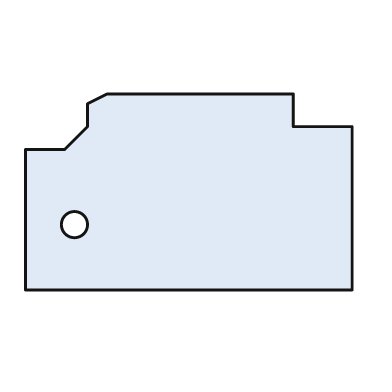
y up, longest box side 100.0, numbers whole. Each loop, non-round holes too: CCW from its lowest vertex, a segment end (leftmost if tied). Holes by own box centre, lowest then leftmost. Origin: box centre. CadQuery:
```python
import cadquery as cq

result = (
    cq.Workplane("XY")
    .moveTo(-50.0, -30.0)
    .lineTo(50.0, -30.0)
    .lineTo(50.0, 20.0)
    .lineTo(32.0, 20.0)
    .lineTo(32.0, 30.0)
    .lineTo(-25.0, 30.0)
    .lineTo(-31.0, 27.0)
    .lineTo(-31.0, 20.0)
    .lineTo(-38.0, 13.0)
    .lineTo(-50.0, 13.0)
    .close()
    .moveTo(-35.0, -10.0)
    .circle(4.0)
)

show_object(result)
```